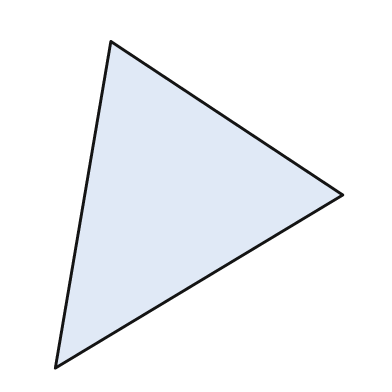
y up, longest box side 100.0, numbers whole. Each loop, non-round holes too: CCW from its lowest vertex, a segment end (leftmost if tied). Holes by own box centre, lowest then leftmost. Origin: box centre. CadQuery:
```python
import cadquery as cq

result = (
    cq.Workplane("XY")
    .moveTo(-44.0, -50.0)
    .lineTo(44.0, 3.0)
    .lineTo(-27.0, 50.0)
    .close()
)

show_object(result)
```